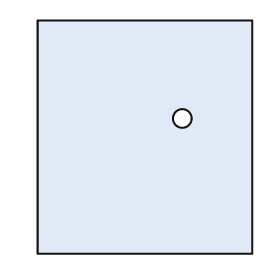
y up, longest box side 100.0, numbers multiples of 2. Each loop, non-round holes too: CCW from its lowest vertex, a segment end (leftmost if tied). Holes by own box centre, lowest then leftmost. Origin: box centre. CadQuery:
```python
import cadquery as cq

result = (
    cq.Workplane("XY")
    .moveTo(-46.0, -50.0)
    .lineTo(46.0, -50.0)
    .lineTo(46.0, 50.0)
    .lineTo(-46.0, 50.0)
    .close()
    .moveTo(16.0, 8.0)
    .circle(4.0)
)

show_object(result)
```